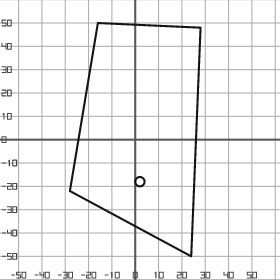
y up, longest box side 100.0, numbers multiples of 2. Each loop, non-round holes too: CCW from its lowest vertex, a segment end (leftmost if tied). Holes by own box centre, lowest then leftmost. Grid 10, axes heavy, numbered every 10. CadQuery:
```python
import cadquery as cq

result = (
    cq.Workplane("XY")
    .moveTo(24.0, -50.0)
    .lineTo(28.0, 48.0)
    .lineTo(-16.0, 50.0)
    .lineTo(-28.0, -22.0)
    .close()
    .moveTo(2.0, -18.0)
    .circle(2.0)
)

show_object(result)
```